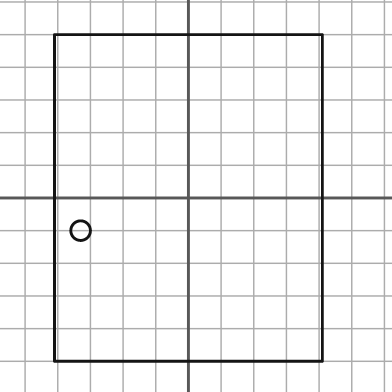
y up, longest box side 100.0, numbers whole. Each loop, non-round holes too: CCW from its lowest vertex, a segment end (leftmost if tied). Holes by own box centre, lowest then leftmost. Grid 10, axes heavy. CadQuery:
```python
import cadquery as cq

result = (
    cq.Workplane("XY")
    .moveTo(-41.0, -50.0)
    .lineTo(41.0, -50.0)
    .lineTo(41.0, 50.0)
    .lineTo(-41.0, 50.0)
    .close()
    .moveTo(-33.0, -10.0)
    .circle(3.0)
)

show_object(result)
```